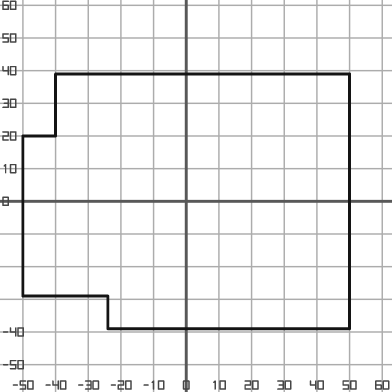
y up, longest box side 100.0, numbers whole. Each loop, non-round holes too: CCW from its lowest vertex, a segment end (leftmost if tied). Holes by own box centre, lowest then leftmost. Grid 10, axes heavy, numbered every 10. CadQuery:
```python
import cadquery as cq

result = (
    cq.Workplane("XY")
    .moveTo(-24.0, -39.0)
    .lineTo(50.0, -39.0)
    .lineTo(50.0, 39.0)
    .lineTo(-40.0, 39.0)
    .lineTo(-40.0, 20.0)
    .lineTo(-50.0, 20.0)
    .lineTo(-50.0, -29.0)
    .lineTo(-24.0, -29.0)
    .close()
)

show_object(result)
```